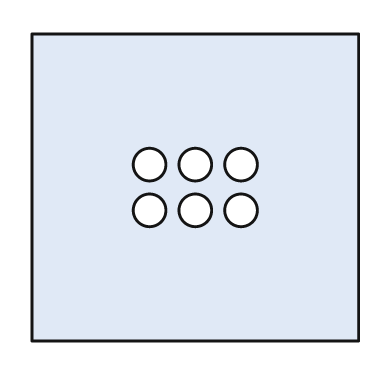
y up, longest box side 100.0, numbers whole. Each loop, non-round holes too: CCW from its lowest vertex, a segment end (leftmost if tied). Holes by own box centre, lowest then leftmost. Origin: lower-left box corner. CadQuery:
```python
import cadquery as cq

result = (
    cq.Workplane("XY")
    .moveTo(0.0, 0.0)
    .lineTo(100.0, 0.0)
    .lineTo(100.0, 94.0)
    .lineTo(0.0, 94.0)
    .close()
    .moveTo(36.0, 40.0)
    .circle(5.0)
    .moveTo(50.0, 40.0)
    .circle(5.0)
    .moveTo(64.0, 40.0)
    .circle(5.0)
    .moveTo(36.0, 54.0)
    .circle(5.0)
    .moveTo(50.0, 54.0)
    .circle(5.0)
    .moveTo(64.0, 54.0)
    .circle(5.0)
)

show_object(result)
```